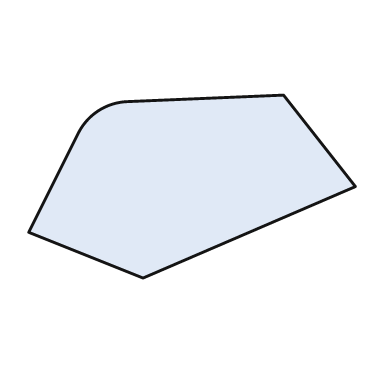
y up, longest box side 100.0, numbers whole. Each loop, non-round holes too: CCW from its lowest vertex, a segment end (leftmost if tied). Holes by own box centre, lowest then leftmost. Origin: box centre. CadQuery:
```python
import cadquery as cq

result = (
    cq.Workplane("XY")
    .moveTo(-15.0, -28.0)
    .lineTo(50.0, 0.0)
    .lineTo(28.0, 28.0)
    .lineTo(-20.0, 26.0)
    .threePointArc((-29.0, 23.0), (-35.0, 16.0))
    .lineTo(-50.0, -14.0)
    .close()
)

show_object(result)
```